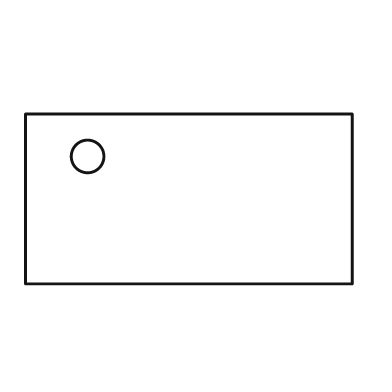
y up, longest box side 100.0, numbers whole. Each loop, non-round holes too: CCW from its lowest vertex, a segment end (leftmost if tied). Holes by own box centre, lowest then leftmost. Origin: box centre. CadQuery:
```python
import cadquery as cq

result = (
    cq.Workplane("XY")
    .moveTo(-50.0, -26.0)
    .lineTo(50.0, -26.0)
    .lineTo(50.0, 26.0)
    .lineTo(-50.0, 26.0)
    .close()
    .moveTo(-31.0, 13.0)
    .circle(5.0)
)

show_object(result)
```